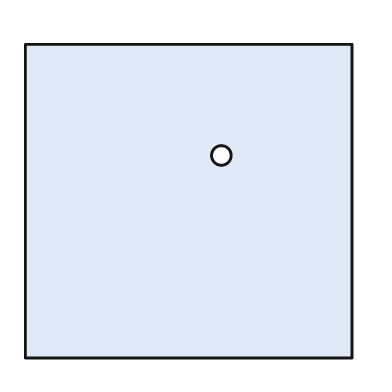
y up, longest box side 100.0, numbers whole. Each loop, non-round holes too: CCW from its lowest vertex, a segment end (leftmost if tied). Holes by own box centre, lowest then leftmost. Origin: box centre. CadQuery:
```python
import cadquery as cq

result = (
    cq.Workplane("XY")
    .moveTo(-50.0, -48.0)
    .lineTo(50.0, -48.0)
    .lineTo(50.0, 48.0)
    .lineTo(-50.0, 48.0)
    .close()
    .moveTo(10.0, 14.0)
    .circle(3.0)
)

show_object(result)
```